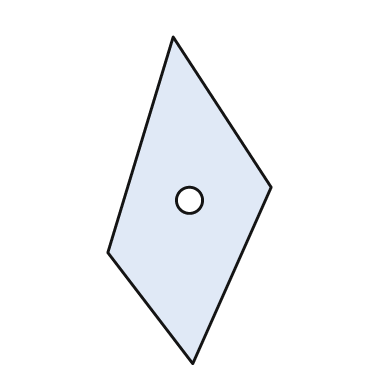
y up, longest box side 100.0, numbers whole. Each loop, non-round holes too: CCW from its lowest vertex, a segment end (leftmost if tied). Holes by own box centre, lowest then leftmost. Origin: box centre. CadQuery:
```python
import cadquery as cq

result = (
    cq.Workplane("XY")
    .moveTo(1.0, -50.0)
    .lineTo(25.0, 4.0)
    .lineTo(-5.0, 50.0)
    .lineTo(-25.0, -16.0)
    .close()
    .moveTo(0.0, 0.0)
    .circle(4.0)
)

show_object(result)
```